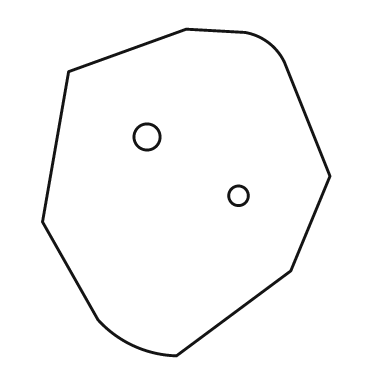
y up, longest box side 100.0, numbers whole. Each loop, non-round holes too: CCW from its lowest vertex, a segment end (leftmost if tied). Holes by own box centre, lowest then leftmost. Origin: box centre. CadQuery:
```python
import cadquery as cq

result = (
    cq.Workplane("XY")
    .moveTo(-3.0, -50.0)
    .lineTo(32.0, -24.0)
    .lineTo(44.0, 5.0)
    .lineTo(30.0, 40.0)
    .threePointArc((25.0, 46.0), (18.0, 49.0))
    .lineTo(0.0, 50.0)
    .lineTo(-36.0, 37.0)
    .lineTo(-44.0, -9.0)
    .lineTo(-27.0, -39.0)
    .threePointArc((-16.0, -47.0), (-3.0, -50.0))
    .close()
    .moveTo(16.0, -1.0)
    .circle(3.0)
    .moveTo(-12.0, 17.0)
    .circle(4.0)
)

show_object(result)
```